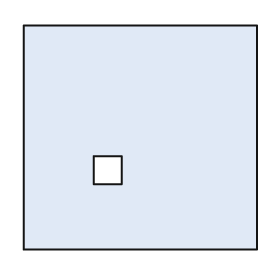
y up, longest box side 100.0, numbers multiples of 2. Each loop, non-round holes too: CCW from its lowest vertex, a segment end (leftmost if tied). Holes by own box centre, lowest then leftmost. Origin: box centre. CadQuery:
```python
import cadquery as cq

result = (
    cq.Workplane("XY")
    .moveTo(-50.0, -48.0)
    .lineTo(50.0, -48.0)
    .lineTo(50.0, 48.0)
    .lineTo(-50.0, 48.0)
    .close()
    .moveTo(-20.0, -20.0)
    .lineTo(-8.0, -20.0)
    .lineTo(-8.0, -8.0)
    .lineTo(-20.0, -8.0)
    .close()
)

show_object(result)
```